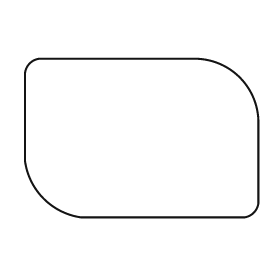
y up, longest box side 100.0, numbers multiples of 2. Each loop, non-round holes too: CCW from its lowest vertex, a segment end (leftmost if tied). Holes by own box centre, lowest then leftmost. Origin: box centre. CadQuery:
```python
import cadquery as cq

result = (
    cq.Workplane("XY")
    .moveTo(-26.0, -34.0)
    .lineTo(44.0, -34.0)
    .threePointArc((48.0, -32.0), (50.0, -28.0))
    .lineTo(50.0, 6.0)
    .threePointArc((42.0, 26.0), (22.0, 34.0))
    .lineTo(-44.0, 34.0)
    .threePointArc((-48.0, 32.0), (-50.0, 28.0))
    .lineTo(-50.0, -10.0)
    .threePointArc((-42.0, -26.0), (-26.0, -34.0))
    .close()
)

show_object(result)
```